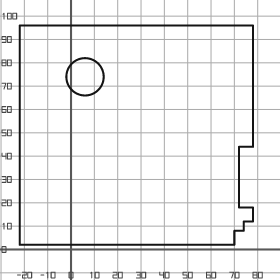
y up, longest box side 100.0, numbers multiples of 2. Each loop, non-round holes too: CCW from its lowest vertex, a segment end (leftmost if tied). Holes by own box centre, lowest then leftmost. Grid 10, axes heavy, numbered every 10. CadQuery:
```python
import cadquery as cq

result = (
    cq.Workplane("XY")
    .moveTo(-22.0, 2.0)
    .lineTo(70.0, 2.0)
    .lineTo(70.0, 8.0)
    .lineTo(74.0, 8.0)
    .lineTo(74.0, 12.0)
    .lineTo(78.0, 12.0)
    .lineTo(78.0, 18.0)
    .lineTo(72.0, 18.0)
    .lineTo(72.0, 44.0)
    .lineTo(78.0, 44.0)
    .lineTo(78.0, 96.0)
    .lineTo(-22.0, 96.0)
    .close()
    .moveTo(6.0, 74.0)
    .circle(8.0)
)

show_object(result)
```